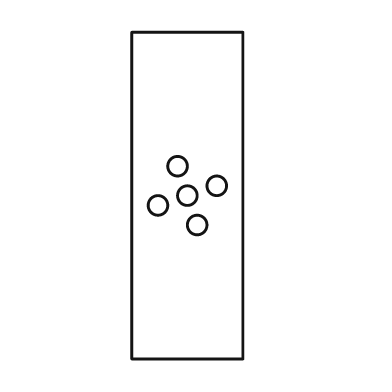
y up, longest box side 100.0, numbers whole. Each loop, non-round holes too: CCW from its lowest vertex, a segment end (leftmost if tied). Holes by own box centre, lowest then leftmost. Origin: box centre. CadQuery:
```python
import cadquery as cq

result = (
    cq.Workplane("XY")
    .moveTo(-17.0, -50.0)
    .lineTo(17.0, -50.0)
    .lineTo(17.0, 50.0)
    .lineTo(-17.0, 50.0)
    .close()
    .moveTo(3.0, -9.0)
    .circle(3.0)
    .moveTo(-9.0, -3.0)
    .circle(3.0)
    .moveTo(0.0, 0.0)
    .circle(3.0)
    .moveTo(9.0, 3.0)
    .circle(3.0)
    .moveTo(-3.0, 9.0)
    .circle(3.0)
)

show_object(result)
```